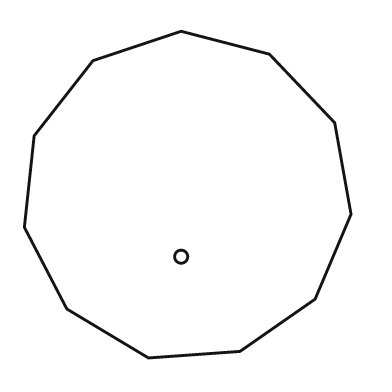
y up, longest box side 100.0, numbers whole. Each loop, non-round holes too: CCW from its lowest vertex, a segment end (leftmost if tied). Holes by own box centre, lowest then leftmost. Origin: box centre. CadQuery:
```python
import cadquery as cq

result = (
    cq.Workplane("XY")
    .moveTo(-12.0, -50.0)
    .lineTo(16.0, -48.0)
    .lineTo(39.0, -32.0)
    .lineTo(50.0, -6.0)
    .lineTo(45.0, 22.0)
    .lineTo(25.0, 43.0)
    .lineTo(-2.0, 50.0)
    .lineTo(-29.0, 41.0)
    .lineTo(-47.0, 18.0)
    .lineTo(-50.0, -10.0)
    .lineTo(-37.0, -35.0)
    .close()
    .moveTo(-2.0, -19.0)
    .circle(2.0)
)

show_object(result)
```